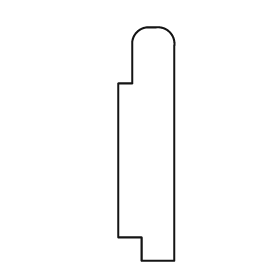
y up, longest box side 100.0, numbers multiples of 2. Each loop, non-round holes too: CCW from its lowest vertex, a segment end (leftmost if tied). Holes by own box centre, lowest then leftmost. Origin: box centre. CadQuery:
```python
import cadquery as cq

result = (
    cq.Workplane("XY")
    .moveTo(-2.0, -50.0)
    .lineTo(12.0, -50.0)
    .lineTo(12.0, 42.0)
    .threePointArc((10.0, 48.0), (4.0, 50.0))
    .lineTo(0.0, 50.0)
    .threePointArc((-4.0, 48.0), (-6.0, 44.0))
    .lineTo(-6.0, 26.0)
    .lineTo(-12.0, 26.0)
    .lineTo(-12.0, -40.0)
    .lineTo(-2.0, -40.0)
    .close()
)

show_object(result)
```